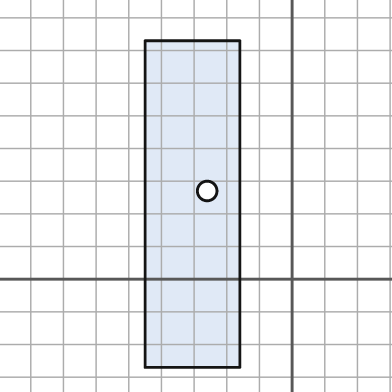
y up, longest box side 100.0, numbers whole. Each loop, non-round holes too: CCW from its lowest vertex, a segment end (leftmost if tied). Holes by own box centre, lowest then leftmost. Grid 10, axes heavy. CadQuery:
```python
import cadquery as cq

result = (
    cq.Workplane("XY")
    .moveTo(-45.0, -27.0)
    .lineTo(-16.0, -27.0)
    .lineTo(-16.0, 73.0)
    .lineTo(-45.0, 73.0)
    .close()
    .moveTo(-26.0, 27.0)
    .circle(3.0)
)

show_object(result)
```